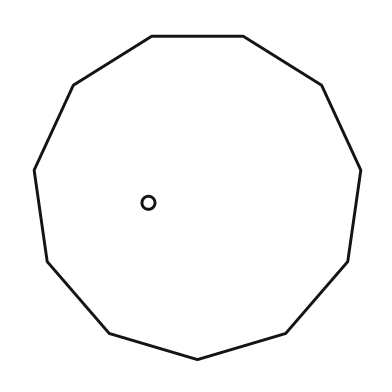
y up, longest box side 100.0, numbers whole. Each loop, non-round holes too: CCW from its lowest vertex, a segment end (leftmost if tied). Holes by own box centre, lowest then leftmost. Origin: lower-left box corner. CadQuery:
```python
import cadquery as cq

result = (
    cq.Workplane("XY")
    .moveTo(50.0, 0.0)
    .lineTo(77.0, 8.0)
    .lineTo(96.0, 30.0)
    .lineTo(100.0, 58.0)
    .lineTo(88.0, 84.0)
    .lineTo(64.0, 99.0)
    .lineTo(36.0, 99.0)
    .lineTo(12.0, 84.0)
    .lineTo(0.0, 58.0)
    .lineTo(4.0, 30.0)
    .lineTo(23.0, 8.0)
    .close()
    .moveTo(35.0, 48.0)
    .circle(2.0)
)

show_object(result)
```